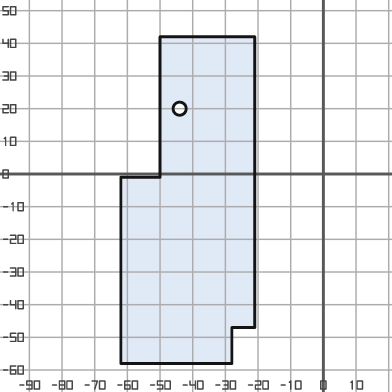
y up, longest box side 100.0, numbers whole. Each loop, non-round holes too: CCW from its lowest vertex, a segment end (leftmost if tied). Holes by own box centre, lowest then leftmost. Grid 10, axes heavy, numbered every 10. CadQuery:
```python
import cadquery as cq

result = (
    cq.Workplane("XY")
    .moveTo(-62.0, -58.0)
    .lineTo(-28.0, -58.0)
    .lineTo(-28.0, -47.0)
    .lineTo(-21.0, -47.0)
    .lineTo(-21.0, 42.0)
    .lineTo(-50.0, 42.0)
    .lineTo(-50.0, -1.0)
    .lineTo(-62.0, -1.0)
    .close()
    .moveTo(-44.0, 20.0)
    .circle(2.0)
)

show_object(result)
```